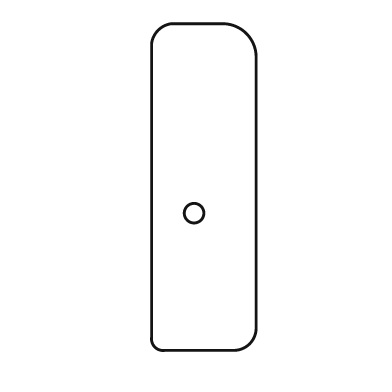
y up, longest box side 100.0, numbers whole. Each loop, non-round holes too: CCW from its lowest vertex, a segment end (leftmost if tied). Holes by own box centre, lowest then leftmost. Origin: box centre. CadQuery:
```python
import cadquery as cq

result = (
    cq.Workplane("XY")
    .moveTo(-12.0, -50.0)
    .lineTo(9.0, -50.0)
    .threePointArc((14.0, -48.0), (16.0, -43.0))
    .lineTo(16.0, 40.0)
    .threePointArc((13.0, 47.0), (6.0, 50.0))
    .lineTo(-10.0, 50.0)
    .threePointArc((-14.0, 48.0), (-16.0, 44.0))
    .lineTo(-16.0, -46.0)
    .threePointArc((-15.0, -49.0), (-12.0, -50.0))
    .close()
    .moveTo(-3.0, -8.0)
    .circle(3.0)
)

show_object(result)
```